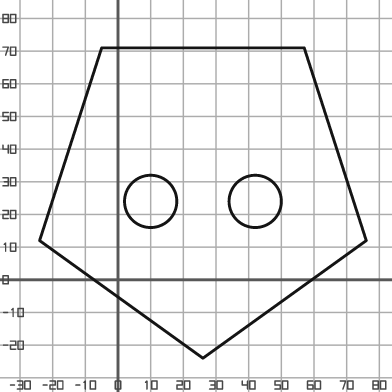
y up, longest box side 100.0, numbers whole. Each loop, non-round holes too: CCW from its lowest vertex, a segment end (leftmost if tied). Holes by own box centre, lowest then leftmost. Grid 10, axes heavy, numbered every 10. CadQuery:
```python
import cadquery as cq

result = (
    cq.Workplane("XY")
    .moveTo(26.0, -24.0)
    .lineTo(76.0, 12.0)
    .lineTo(57.0, 71.0)
    .lineTo(-5.0, 71.0)
    .lineTo(-24.0, 12.0)
    .close()
    .moveTo(10.0, 24.0)
    .circle(8.0)
    .moveTo(42.0, 24.0)
    .circle(8.0)
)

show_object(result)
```